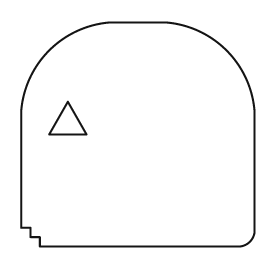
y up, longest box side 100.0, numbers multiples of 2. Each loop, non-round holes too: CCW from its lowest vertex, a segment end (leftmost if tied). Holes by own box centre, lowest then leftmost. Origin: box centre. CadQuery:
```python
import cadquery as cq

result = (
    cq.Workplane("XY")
    .moveTo(-42.0, -48.0)
    .lineTo(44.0, -48.0)
    .threePointArc((48.0, -46.0), (50.0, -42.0))
    .lineTo(50.0, 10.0)
    .threePointArc((38.0, 36.0), (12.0, 48.0))
    .lineTo(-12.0, 48.0)
    .threePointArc((-38.0, 36.0), (-50.0, 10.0))
    .lineTo(-50.0, -40.0)
    .lineTo(-46.0, -40.0)
    .lineTo(-46.0, -44.0)
    .lineTo(-42.0, -44.0)
    .close()
    .moveTo(-38.0, 0.0)
    .lineTo(-22.0, 0.0)
    .lineTo(-30.0, 14.0)
    .close()
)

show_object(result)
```